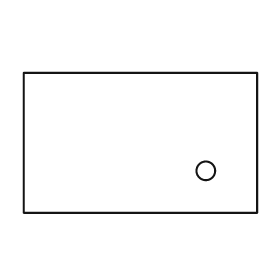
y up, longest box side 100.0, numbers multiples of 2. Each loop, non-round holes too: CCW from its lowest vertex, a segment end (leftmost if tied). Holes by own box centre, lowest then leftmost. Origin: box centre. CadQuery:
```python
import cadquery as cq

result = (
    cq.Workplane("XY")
    .moveTo(-50.0, -30.0)
    .lineTo(50.0, -30.0)
    .lineTo(50.0, 30.0)
    .lineTo(-50.0, 30.0)
    .close()
    .moveTo(28.0, -12.0)
    .circle(4.0)
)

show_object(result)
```